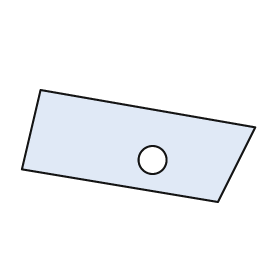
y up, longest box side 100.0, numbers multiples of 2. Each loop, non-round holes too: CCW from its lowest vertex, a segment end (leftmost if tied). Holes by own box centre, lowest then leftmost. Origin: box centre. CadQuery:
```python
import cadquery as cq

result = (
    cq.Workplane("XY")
    .moveTo(34.0, -24.0)
    .lineTo(50.0, 8.0)
    .lineTo(-42.0, 24.0)
    .lineTo(-50.0, -10.0)
    .close()
    .moveTo(6.0, -6.0)
    .circle(6.0)
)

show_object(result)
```